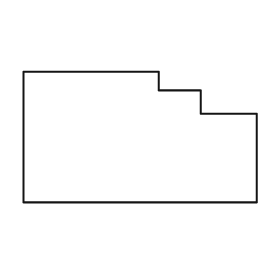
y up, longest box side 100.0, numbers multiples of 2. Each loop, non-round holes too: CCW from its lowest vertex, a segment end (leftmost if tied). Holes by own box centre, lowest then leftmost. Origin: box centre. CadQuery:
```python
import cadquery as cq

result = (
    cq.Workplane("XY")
    .moveTo(-50.0, -28.0)
    .lineTo(50.0, -28.0)
    .lineTo(50.0, 10.0)
    .lineTo(26.0, 10.0)
    .lineTo(26.0, 20.0)
    .lineTo(8.0, 20.0)
    .lineTo(8.0, 28.0)
    .lineTo(-50.0, 28.0)
    .close()
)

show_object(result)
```